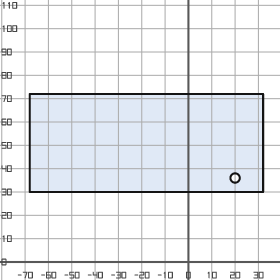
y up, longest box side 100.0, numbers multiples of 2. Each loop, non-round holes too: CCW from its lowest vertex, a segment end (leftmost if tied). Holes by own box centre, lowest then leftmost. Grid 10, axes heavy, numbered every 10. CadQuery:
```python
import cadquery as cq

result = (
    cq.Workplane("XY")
    .moveTo(-68.0, 30.0)
    .lineTo(32.0, 30.0)
    .lineTo(32.0, 72.0)
    .lineTo(-68.0, 72.0)
    .close()
    .moveTo(20.0, 36.0)
    .circle(2.0)
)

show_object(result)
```